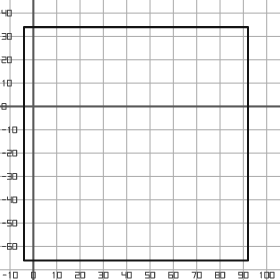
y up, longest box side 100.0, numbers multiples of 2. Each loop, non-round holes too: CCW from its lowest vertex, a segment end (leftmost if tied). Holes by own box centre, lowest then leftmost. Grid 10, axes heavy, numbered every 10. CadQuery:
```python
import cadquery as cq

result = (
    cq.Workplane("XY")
    .moveTo(-4.0, -66.0)
    .lineTo(92.0, -66.0)
    .lineTo(92.0, 34.0)
    .lineTo(-4.0, 34.0)
    .close()
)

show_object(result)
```